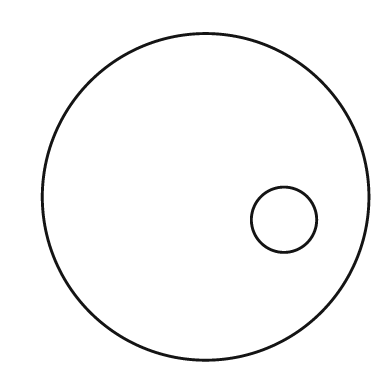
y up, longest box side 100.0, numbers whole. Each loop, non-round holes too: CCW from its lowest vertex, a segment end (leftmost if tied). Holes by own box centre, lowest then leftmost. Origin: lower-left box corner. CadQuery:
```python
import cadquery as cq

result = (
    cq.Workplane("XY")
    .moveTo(50.0, 50.0)
    .circle(50.0)
    .moveTo(74.0, 43.0)
    .circle(10.0)
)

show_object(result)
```